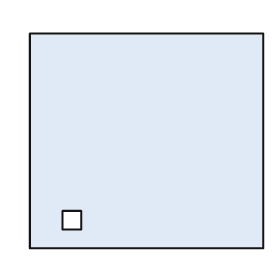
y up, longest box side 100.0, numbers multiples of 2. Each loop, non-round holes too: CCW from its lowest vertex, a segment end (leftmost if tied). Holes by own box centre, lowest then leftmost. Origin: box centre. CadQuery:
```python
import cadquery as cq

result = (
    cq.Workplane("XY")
    .moveTo(-50.0, -46.0)
    .lineTo(50.0, -46.0)
    .lineTo(50.0, 46.0)
    .lineTo(-50.0, 46.0)
    .close()
    .moveTo(-36.0, -38.0)
    .lineTo(-28.0, -38.0)
    .lineTo(-28.0, -30.0)
    .lineTo(-36.0, -30.0)
    .close()
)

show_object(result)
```